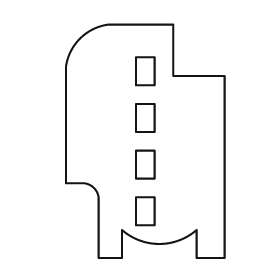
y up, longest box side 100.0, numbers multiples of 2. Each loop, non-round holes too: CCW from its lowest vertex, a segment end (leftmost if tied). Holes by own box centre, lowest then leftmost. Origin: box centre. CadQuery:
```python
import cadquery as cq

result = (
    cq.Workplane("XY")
    .moveTo(-20.0, -50.0)
    .lineTo(-10.0, -50.0)
    .lineTo(-10.0, -38.0)
    .threePointArc((6.0, -44.0), (22.0, -38.0))
    .lineTo(22.0, -50.0)
    .lineTo(34.0, -50.0)
    .lineTo(34.0, 28.0)
    .lineTo(12.0, 28.0)
    .lineTo(12.0, 50.0)
    .lineTo(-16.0, 50.0)
    .threePointArc((-28.0, 44.0), (-34.0, 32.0))
    .lineTo(-34.0, -18.0)
    .lineTo(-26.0, -18.0)
    .threePointArc((-22.0, -20.0), (-20.0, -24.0))
    .close()
    .moveTo(-4.0, -36.0)
    .lineTo(4.0, -36.0)
    .lineTo(4.0, -24.0)
    .lineTo(-4.0, -24.0)
    .close()
    .moveTo(-4.0, -16.0)
    .lineTo(4.0, -16.0)
    .lineTo(4.0, -4.0)
    .lineTo(-4.0, -4.0)
    .close()
    .moveTo(-4.0, 4.0)
    .lineTo(4.0, 4.0)
    .lineTo(4.0, 16.0)
    .lineTo(-4.0, 16.0)
    .close()
    .moveTo(-4.0, 24.0)
    .lineTo(4.0, 24.0)
    .lineTo(4.0, 36.0)
    .lineTo(-4.0, 36.0)
    .close()
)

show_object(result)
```